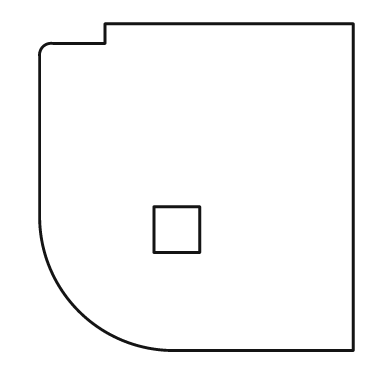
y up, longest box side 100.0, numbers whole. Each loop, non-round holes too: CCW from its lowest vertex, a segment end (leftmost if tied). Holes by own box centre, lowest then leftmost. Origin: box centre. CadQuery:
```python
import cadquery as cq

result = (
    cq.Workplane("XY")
    .moveTo(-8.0, -50.0)
    .lineTo(48.0, -50.0)
    .lineTo(48.0, 50.0)
    .lineTo(-28.0, 50.0)
    .lineTo(-28.0, 44.0)
    .lineTo(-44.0, 44.0)
    .threePointArc((-47.0, 43.0), (-48.0, 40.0))
    .lineTo(-48.0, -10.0)
    .threePointArc((-36.0, -38.0), (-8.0, -50.0))
    .close()
    .moveTo(-13.0, -20.0)
    .lineTo(1.0, -20.0)
    .lineTo(1.0, -6.0)
    .lineTo(-13.0, -6.0)
    .close()
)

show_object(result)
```